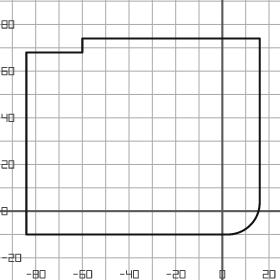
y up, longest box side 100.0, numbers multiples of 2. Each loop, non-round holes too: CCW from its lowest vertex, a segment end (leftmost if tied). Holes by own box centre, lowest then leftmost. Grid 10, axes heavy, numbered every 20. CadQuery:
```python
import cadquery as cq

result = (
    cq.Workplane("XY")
    .moveTo(-84.0, -10.0)
    .lineTo(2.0, -10.0)
    .threePointArc((12.0, -6.0), (16.0, 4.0))
    .lineTo(16.0, 74.0)
    .lineTo(-60.0, 74.0)
    .lineTo(-60.0, 68.0)
    .lineTo(-84.0, 68.0)
    .close()
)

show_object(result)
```